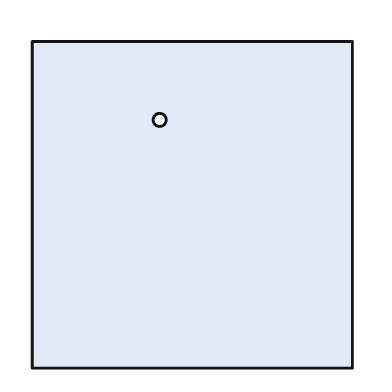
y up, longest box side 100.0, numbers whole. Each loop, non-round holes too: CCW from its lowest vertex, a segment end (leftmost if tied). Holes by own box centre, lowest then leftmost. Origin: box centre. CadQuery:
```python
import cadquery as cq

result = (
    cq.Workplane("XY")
    .moveTo(-49.0, -50.0)
    .lineTo(49.0, -50.0)
    .lineTo(49.0, 50.0)
    .lineTo(-49.0, 50.0)
    .close()
    .moveTo(-10.0, 26.0)
    .circle(2.0)
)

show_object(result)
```